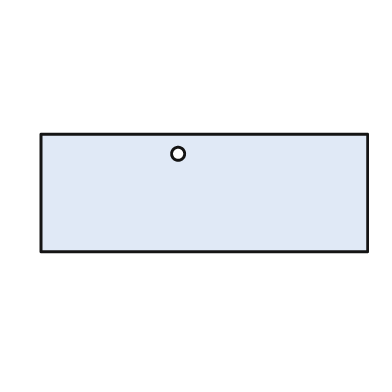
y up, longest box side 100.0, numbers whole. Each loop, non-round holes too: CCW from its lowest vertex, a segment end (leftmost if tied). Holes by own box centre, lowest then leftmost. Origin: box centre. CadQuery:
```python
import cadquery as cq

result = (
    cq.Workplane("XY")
    .moveTo(-50.0, -18.0)
    .lineTo(50.0, -18.0)
    .lineTo(50.0, 18.0)
    .lineTo(-50.0, 18.0)
    .close()
    .moveTo(-8.0, 12.0)
    .circle(2.0)
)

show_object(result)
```